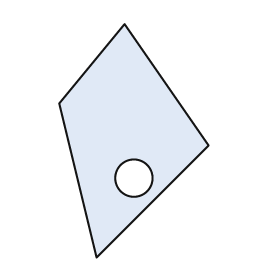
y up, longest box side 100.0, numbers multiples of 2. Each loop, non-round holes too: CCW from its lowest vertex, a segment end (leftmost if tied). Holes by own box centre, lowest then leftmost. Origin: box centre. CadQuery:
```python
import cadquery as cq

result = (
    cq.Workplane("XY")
    .moveTo(-16.0, -50.0)
    .lineTo(32.0, -2.0)
    .lineTo(-4.0, 50.0)
    .lineTo(-32.0, 16.0)
    .close()
    .moveTo(0.0, -16.0)
    .circle(8.0)
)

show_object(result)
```